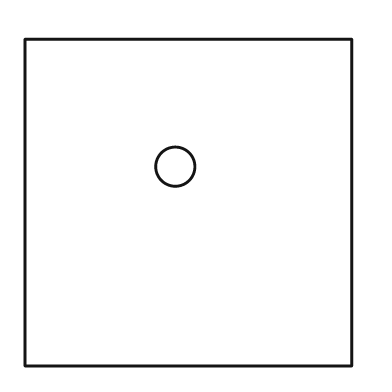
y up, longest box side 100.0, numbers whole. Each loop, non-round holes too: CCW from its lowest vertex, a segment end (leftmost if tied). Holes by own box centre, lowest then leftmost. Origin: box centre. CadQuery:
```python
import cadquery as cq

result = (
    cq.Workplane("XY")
    .moveTo(-50.0, -50.0)
    .lineTo(50.0, -50.0)
    .lineTo(50.0, 50.0)
    .lineTo(-50.0, 50.0)
    .close()
    .moveTo(-4.0, 11.0)
    .circle(6.0)
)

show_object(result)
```